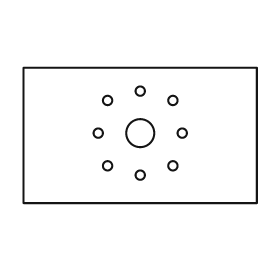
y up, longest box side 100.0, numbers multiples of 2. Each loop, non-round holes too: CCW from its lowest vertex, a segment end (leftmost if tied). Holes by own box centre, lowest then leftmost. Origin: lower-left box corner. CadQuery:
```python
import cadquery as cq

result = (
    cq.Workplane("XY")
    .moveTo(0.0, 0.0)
    .lineTo(100.0, 0.0)
    .lineTo(100.0, 58.0)
    .lineTo(0.0, 58.0)
    .close()
    .moveTo(50.0, 12.0)
    .circle(2.0)
    .moveTo(36.0, 16.0)
    .circle(2.0)
    .moveTo(64.0, 16.0)
    .circle(2.0)
    .moveTo(32.0, 30.0)
    .circle(2.0)
    .moveTo(50.0, 30.0)
    .circle(6.0)
    .moveTo(68.0, 30.0)
    .circle(2.0)
    .moveTo(36.0, 44.0)
    .circle(2.0)
    .moveTo(64.0, 44.0)
    .circle(2.0)
    .moveTo(50.0, 48.0)
    .circle(2.0)
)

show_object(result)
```